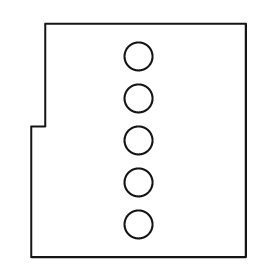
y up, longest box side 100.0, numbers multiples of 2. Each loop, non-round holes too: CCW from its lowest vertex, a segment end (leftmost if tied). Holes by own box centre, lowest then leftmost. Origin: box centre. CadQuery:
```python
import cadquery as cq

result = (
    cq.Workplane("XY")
    .moveTo(-46.0, -50.0)
    .lineTo(46.0, -50.0)
    .lineTo(46.0, 50.0)
    .lineTo(-40.0, 50.0)
    .lineTo(-40.0, 6.0)
    .lineTo(-46.0, 6.0)
    .close()
    .moveTo(0.0, -36.0)
    .circle(6.0)
    .moveTo(0.0, -18.0)
    .circle(6.0)
    .moveTo(0.0, 0.0)
    .circle(6.0)
    .moveTo(0.0, 18.0)
    .circle(6.0)
    .moveTo(0.0, 36.0)
    .circle(6.0)
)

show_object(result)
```